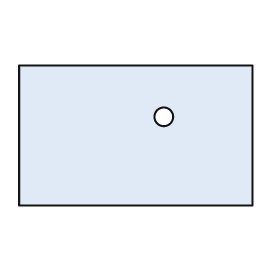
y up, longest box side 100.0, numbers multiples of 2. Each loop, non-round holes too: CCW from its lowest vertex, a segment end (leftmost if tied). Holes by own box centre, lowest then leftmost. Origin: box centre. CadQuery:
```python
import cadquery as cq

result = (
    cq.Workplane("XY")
    .moveTo(-50.0, -30.0)
    .lineTo(50.0, -30.0)
    .lineTo(50.0, 30.0)
    .lineTo(-50.0, 30.0)
    .close()
    .moveTo(12.0, 8.0)
    .circle(4.0)
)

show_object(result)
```